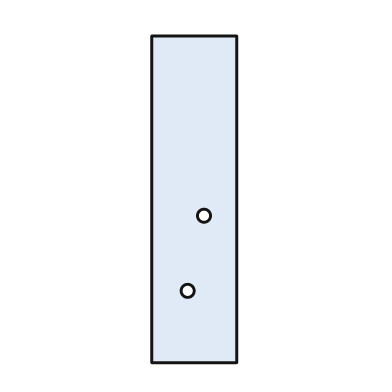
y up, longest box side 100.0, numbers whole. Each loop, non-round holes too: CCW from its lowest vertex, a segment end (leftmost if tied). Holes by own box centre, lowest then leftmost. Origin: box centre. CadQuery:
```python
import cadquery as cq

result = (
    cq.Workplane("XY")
    .moveTo(-13.0, -50.0)
    .lineTo(13.0, -50.0)
    .lineTo(13.0, 50.0)
    .lineTo(-13.0, 50.0)
    .close()
    .moveTo(-2.0, -28.0)
    .circle(2.0)
    .moveTo(3.0, -5.0)
    .circle(2.0)
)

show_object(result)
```